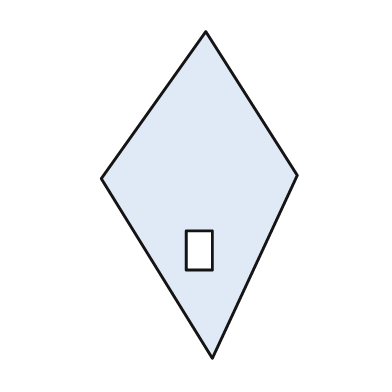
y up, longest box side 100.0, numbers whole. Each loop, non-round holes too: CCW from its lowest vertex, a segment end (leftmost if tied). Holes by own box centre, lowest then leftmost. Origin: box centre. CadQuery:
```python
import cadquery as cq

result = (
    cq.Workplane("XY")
    .moveTo(4.0, -50.0)
    .lineTo(30.0, 6.0)
    .lineTo(2.0, 50.0)
    .lineTo(-30.0, 5.0)
    .close()
    .moveTo(-4.0, -23.0)
    .lineTo(4.0, -23.0)
    .lineTo(4.0, -11.0)
    .lineTo(-4.0, -11.0)
    .close()
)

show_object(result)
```